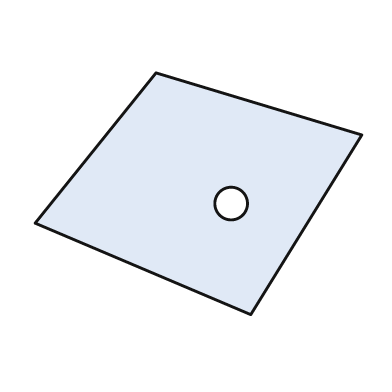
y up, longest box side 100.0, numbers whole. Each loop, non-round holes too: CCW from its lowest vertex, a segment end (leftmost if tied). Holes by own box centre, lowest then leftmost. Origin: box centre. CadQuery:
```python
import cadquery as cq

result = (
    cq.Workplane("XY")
    .moveTo(16.0, -37.0)
    .lineTo(50.0, 18.0)
    .lineTo(-13.0, 37.0)
    .lineTo(-50.0, -9.0)
    .close()
    .moveTo(10.0, -3.0)
    .circle(5.0)
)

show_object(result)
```